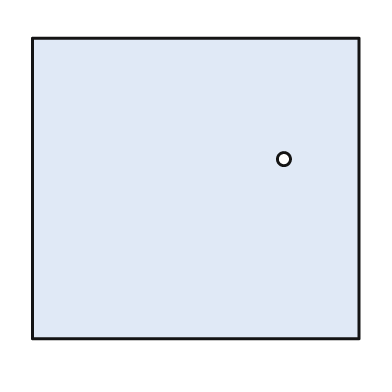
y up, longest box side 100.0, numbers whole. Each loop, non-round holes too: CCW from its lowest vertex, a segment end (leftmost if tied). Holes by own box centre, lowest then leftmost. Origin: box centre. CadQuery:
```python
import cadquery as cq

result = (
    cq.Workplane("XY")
    .moveTo(-50.0, -46.0)
    .lineTo(50.0, -46.0)
    .lineTo(50.0, 46.0)
    .lineTo(-50.0, 46.0)
    .close()
    .moveTo(27.0, 9.0)
    .circle(2.0)
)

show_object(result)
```